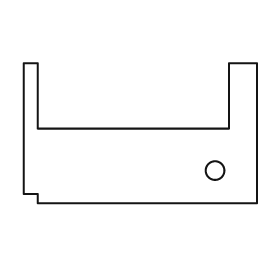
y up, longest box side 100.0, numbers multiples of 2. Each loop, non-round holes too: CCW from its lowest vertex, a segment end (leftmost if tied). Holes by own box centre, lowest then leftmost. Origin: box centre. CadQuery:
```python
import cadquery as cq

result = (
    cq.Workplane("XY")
    .moveTo(-44.0, -30.0)
    .lineTo(50.0, -30.0)
    .lineTo(50.0, 30.0)
    .lineTo(38.0, 30.0)
    .lineTo(38.0, 2.0)
    .lineTo(-44.0, 2.0)
    .lineTo(-44.0, 30.0)
    .lineTo(-50.0, 30.0)
    .lineTo(-50.0, -26.0)
    .lineTo(-44.0, -26.0)
    .close()
    .moveTo(32.0, -16.0)
    .circle(4.0)
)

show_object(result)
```